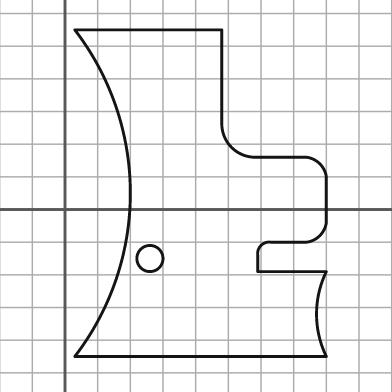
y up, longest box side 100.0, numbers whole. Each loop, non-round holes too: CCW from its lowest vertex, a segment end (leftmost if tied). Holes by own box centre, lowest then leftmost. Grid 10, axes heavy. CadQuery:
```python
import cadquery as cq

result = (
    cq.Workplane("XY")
    .moveTo(3.0, -45.0)
    .lineTo(80.0, -45.0)
    .threePointArc((77.0, -32.0), (80.0, -19.0))
    .lineTo(59.0, -19.0)
    .lineTo(59.0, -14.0)
    .threePointArc((60.0, -11.0), (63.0, -10.0))
    .lineTo(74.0, -10.0)
    .threePointArc((78.0, -8.0), (80.0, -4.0))
    .lineTo(80.0, 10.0)
    .threePointArc((78.0, 14.0), (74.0, 16.0))
    .lineTo(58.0, 16.0)
    .threePointArc((51.0, 19.0), (48.0, 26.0))
    .lineTo(48.0, 55.0)
    .lineTo(3.0, 55.0)
    .threePointArc((20.0, 5.0), (3.0, -45.0))
    .close()
    .moveTo(26.0, -15.0)
    .circle(4.0)
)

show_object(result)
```